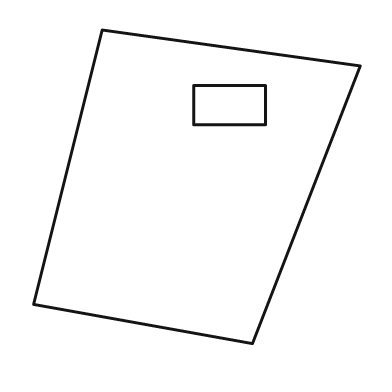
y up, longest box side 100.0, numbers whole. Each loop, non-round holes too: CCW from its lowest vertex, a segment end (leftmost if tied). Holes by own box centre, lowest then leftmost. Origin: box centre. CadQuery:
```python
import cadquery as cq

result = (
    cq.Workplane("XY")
    .moveTo(17.0, -48.0)
    .lineTo(50.0, 37.0)
    .lineTo(-29.0, 48.0)
    .lineTo(-50.0, -36.0)
    .close()
    .moveTo(-1.0, 19.0)
    .lineTo(21.0, 19.0)
    .lineTo(21.0, 31.0)
    .lineTo(-1.0, 31.0)
    .close()
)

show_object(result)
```